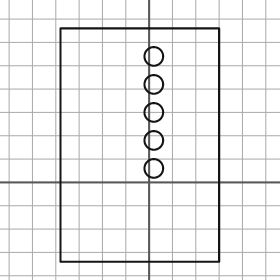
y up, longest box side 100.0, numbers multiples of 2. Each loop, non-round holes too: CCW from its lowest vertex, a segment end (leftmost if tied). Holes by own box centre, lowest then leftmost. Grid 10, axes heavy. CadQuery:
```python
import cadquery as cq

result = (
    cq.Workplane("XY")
    .moveTo(-38.0, -34.0)
    .lineTo(30.0, -34.0)
    .lineTo(30.0, 66.0)
    .lineTo(-38.0, 66.0)
    .close()
    .moveTo(2.0, 6.0)
    .circle(4.0)
    .moveTo(2.0, 18.0)
    .circle(4.0)
    .moveTo(2.0, 30.0)
    .circle(4.0)
    .moveTo(2.0, 42.0)
    .circle(4.0)
    .moveTo(2.0, 54.0)
    .circle(4.0)
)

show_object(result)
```